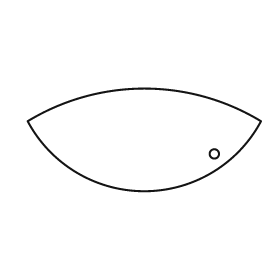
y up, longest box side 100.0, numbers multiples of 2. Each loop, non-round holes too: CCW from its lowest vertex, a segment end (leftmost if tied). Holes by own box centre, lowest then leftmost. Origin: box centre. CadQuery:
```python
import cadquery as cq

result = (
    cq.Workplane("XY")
    .moveTo(-50.0, 8.0)
    .threePointArc((0.0, -22.0), (50.0, 8.0))
    .threePointArc((0.0, 22.0), (-50.0, 8.0))
    .close()
    .moveTo(30.0, -6.0)
    .circle(2.0)
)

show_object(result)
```